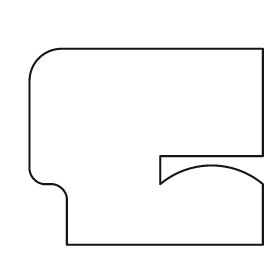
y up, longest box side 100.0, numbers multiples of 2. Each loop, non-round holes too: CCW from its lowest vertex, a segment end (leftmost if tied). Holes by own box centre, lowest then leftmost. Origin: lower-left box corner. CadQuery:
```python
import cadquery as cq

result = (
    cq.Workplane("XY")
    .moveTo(16.0, 0.0)
    .lineTo(100.0, 0.0)
    .lineTo(100.0, 26.0)
    .threePointArc((78.0, 34.0), (56.0, 26.0))
    .lineTo(56.0, 38.0)
    .lineTo(100.0, 38.0)
    .lineTo(100.0, 84.0)
    .lineTo(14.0, 84.0)
    .threePointArc((4.0, 80.0), (0.0, 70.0))
    .lineTo(0.0, 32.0)
    .threePointArc((2.0, 28.0), (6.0, 26.0))
    .lineTo(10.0, 26.0)
    .threePointArc((14.0, 24.0), (16.0, 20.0))
    .close()
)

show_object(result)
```